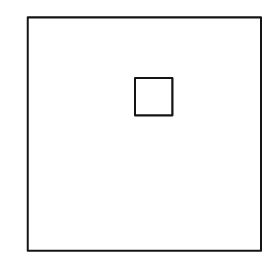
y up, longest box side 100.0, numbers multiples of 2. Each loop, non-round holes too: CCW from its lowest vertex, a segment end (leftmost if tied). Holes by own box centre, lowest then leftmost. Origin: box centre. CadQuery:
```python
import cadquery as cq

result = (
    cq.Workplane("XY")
    .moveTo(-50.0, -50.0)
    .lineTo(50.0, -50.0)
    .lineTo(50.0, 50.0)
    .lineTo(-50.0, 50.0)
    .close()
    .moveTo(-4.0, 8.0)
    .lineTo(12.0, 8.0)
    .lineTo(12.0, 24.0)
    .lineTo(-4.0, 24.0)
    .close()
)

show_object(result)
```